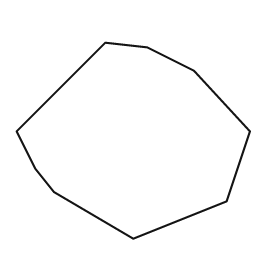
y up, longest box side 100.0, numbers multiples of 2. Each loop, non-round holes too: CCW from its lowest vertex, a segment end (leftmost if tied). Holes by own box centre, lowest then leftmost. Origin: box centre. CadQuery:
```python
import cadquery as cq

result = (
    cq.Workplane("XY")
    .moveTo(0.0, -42.0)
    .lineTo(40.0, -26.0)
    .lineTo(50.0, 4.0)
    .lineTo(26.0, 30.0)
    .lineTo(6.0, 40.0)
    .lineTo(-12.0, 42.0)
    .lineTo(-50.0, 4.0)
    .lineTo(-42.0, -12.0)
    .lineTo(-34.0, -22.0)
    .close()
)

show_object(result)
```